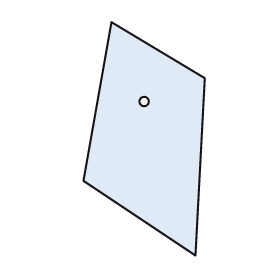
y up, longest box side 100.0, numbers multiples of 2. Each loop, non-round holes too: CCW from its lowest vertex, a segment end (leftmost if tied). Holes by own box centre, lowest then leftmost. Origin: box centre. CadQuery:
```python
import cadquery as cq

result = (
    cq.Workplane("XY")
    .moveTo(22.0, -50.0)
    .lineTo(26.0, 26.0)
    .lineTo(-14.0, 50.0)
    .lineTo(-26.0, -18.0)
    .close()
    .moveTo(0.0, 16.0)
    .circle(2.0)
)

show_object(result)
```